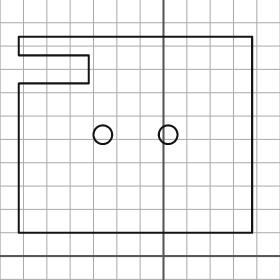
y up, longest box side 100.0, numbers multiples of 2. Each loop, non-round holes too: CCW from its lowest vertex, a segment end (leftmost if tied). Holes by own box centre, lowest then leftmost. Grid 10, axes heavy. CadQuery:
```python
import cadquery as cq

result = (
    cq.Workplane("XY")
    .moveTo(-62.0, 10.0)
    .lineTo(38.0, 10.0)
    .lineTo(38.0, 94.0)
    .lineTo(-62.0, 94.0)
    .lineTo(-62.0, 86.0)
    .lineTo(-32.0, 86.0)
    .lineTo(-32.0, 74.0)
    .lineTo(-62.0, 74.0)
    .close()
    .moveTo(-26.0, 52.0)
    .circle(4.0)
    .moveTo(2.0, 52.0)
    .circle(4.0)
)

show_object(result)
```